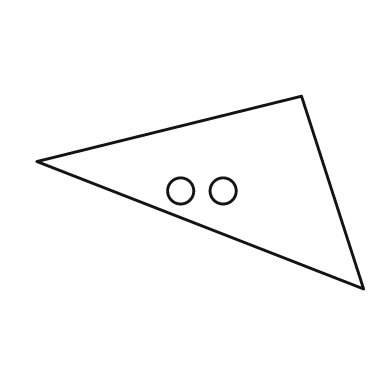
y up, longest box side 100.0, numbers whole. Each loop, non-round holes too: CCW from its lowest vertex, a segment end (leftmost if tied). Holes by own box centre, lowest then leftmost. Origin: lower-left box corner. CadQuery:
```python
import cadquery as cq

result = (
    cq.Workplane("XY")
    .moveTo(100.0, 0.0)
    .lineTo(81.0, 59.0)
    .lineTo(0.0, 39.0)
    .close()
    .moveTo(44.0, 30.0)
    .circle(4.0)
    .moveTo(57.0, 30.0)
    .circle(4.0)
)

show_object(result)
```